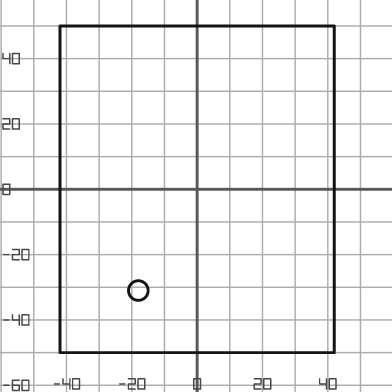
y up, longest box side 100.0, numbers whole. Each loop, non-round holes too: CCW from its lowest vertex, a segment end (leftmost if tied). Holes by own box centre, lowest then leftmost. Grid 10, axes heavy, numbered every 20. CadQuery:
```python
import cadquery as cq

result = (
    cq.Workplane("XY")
    .moveTo(-42.0, -50.0)
    .lineTo(42.0, -50.0)
    .lineTo(42.0, 50.0)
    .lineTo(-42.0, 50.0)
    .close()
    .moveTo(-18.0, -31.0)
    .circle(3.0)
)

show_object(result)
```